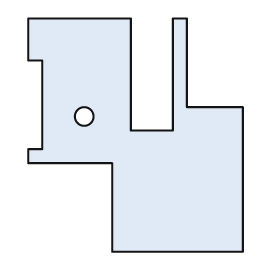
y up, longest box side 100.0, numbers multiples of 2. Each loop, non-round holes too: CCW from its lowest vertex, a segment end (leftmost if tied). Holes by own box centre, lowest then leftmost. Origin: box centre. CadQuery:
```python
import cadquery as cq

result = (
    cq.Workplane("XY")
    .moveTo(-10.0, -50.0)
    .lineTo(46.0, -50.0)
    .lineTo(46.0, 12.0)
    .lineTo(22.0, 12.0)
    .lineTo(22.0, 50.0)
    .lineTo(16.0, 50.0)
    .lineTo(16.0, 2.0)
    .lineTo(-2.0, 2.0)
    .lineTo(-2.0, 50.0)
    .lineTo(-46.0, 50.0)
    .lineTo(-46.0, 32.0)
    .lineTo(-40.0, 32.0)
    .lineTo(-40.0, -6.0)
    .lineTo(-46.0, -6.0)
    .lineTo(-46.0, -12.0)
    .lineTo(-10.0, -12.0)
    .close()
    .moveTo(-22.0, 8.0)
    .circle(4.0)
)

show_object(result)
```